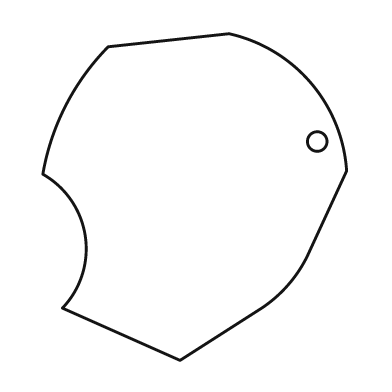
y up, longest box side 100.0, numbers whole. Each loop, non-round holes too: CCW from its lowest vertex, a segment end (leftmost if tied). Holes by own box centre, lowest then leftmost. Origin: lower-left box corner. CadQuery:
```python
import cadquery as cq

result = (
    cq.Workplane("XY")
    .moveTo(42.0, 0.0)
    .lineTo(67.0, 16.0)
    .threePointArc((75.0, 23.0), (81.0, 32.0))
    .lineTo(93.0, 58.0)
    .threePointArc((82.0, 85.0), (57.0, 100.0))
    .lineTo(20.0, 96.0)
    .threePointArc((7.0, 78.0), (0.0, 57.0))
    .threePointArc((13.0, 38.0), (6.0, 16.0))
    .close()
    .moveTo(84.0, 67.0)
    .circle(3.0)
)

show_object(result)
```